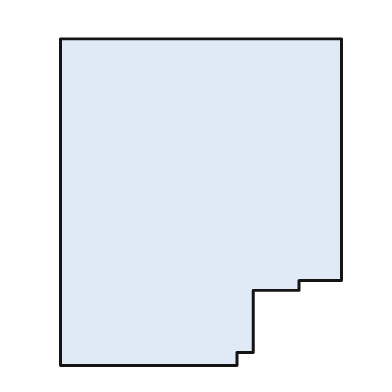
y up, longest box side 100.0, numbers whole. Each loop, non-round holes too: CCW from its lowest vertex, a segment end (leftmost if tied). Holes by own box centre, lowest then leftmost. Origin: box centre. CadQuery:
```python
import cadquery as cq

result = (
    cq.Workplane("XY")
    .moveTo(-43.0, -50.0)
    .lineTo(11.0, -50.0)
    .lineTo(11.0, -46.0)
    .lineTo(16.0, -46.0)
    .lineTo(16.0, -27.0)
    .lineTo(30.0, -27.0)
    .lineTo(30.0, -24.0)
    .lineTo(43.0, -24.0)
    .lineTo(43.0, 50.0)
    .lineTo(-43.0, 50.0)
    .close()
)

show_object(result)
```